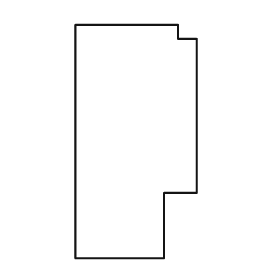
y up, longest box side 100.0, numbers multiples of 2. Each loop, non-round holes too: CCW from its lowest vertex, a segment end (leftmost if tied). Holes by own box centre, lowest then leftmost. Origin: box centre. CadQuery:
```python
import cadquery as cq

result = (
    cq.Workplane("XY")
    .moveTo(-26.0, -50.0)
    .lineTo(12.0, -50.0)
    .lineTo(12.0, -22.0)
    .lineTo(26.0, -22.0)
    .lineTo(26.0, 44.0)
    .lineTo(18.0, 44.0)
    .lineTo(18.0, 50.0)
    .lineTo(-26.0, 50.0)
    .close()
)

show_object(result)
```